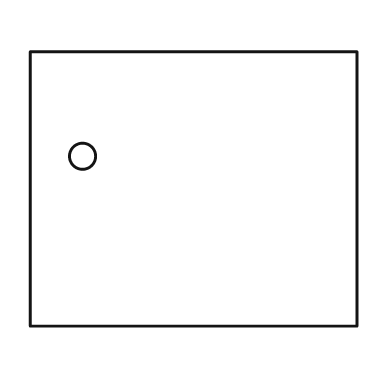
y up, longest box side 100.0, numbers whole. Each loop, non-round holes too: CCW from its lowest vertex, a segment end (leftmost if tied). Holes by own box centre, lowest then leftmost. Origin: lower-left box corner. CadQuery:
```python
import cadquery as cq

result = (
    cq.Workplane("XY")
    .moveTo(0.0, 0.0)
    .lineTo(100.0, 0.0)
    .lineTo(100.0, 84.0)
    .lineTo(0.0, 84.0)
    .close()
    .moveTo(16.0, 52.0)
    .circle(4.0)
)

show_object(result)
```